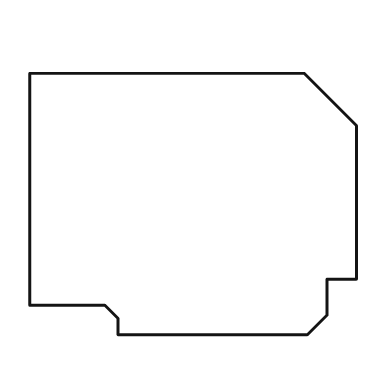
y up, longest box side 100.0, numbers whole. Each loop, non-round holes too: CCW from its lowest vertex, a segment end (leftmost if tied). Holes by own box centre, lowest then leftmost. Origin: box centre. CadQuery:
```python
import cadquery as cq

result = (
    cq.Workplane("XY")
    .moveTo(-23.0, -40.0)
    .lineTo(35.0, -40.0)
    .lineTo(41.0, -34.0)
    .lineTo(41.0, -23.0)
    .lineTo(50.0, -23.0)
    .lineTo(50.0, 24.0)
    .lineTo(34.0, 40.0)
    .lineTo(-50.0, 40.0)
    .lineTo(-50.0, -31.0)
    .lineTo(-27.0, -31.0)
    .lineTo(-23.0, -35.0)
    .close()
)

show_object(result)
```